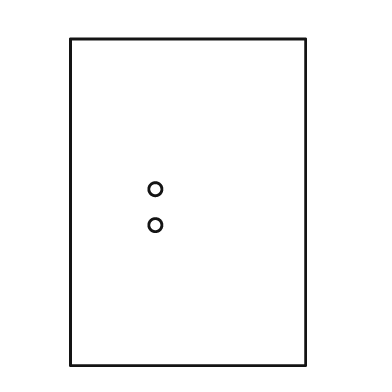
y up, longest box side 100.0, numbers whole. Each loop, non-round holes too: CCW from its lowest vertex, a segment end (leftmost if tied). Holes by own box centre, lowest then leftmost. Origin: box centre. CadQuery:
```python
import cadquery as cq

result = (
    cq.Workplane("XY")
    .moveTo(-36.0, -50.0)
    .lineTo(36.0, -50.0)
    .lineTo(36.0, 50.0)
    .lineTo(-36.0, 50.0)
    .close()
    .moveTo(-10.0, -7.0)
    .circle(2.0)
    .moveTo(-10.0, 4.0)
    .circle(2.0)
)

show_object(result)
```